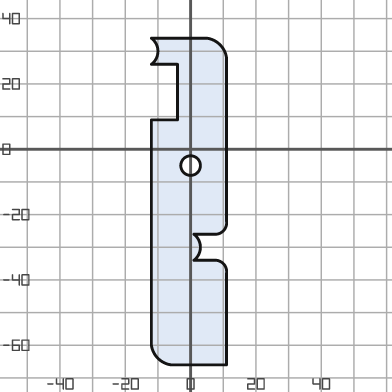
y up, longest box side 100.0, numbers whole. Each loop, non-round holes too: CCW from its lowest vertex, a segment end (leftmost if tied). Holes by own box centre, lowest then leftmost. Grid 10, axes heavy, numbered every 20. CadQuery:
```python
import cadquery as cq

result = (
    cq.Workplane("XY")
    .moveTo(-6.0, -66.0)
    .lineTo(11.0, -66.0)
    .lineTo(11.0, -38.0)
    .threePointArc((10.0, -35.0), (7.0, -34.0))
    .lineTo(1.0, -34.0)
    .threePointArc((3.0, -30.0), (1.0, -26.0))
    .lineTo(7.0, -26.0)
    .threePointArc((10.0, -25.0), (11.0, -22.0))
    .lineTo(11.0, 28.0)
    .threePointArc((9.0, 32.0), (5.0, 34.0))
    .lineTo(-12.0, 34.0)
    .threePointArc((-10.0, 30.0), (-12.0, 26.0))
    .lineTo(-4.0, 26.0)
    .lineTo(-4.0, 9.0)
    .lineTo(-12.0, 9.0)
    .lineTo(-12.0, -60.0)
    .threePointArc((-10.0, -64.0), (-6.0, -66.0))
    .close()
    .moveTo(0.0, -5.0)
    .circle(3.0)
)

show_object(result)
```